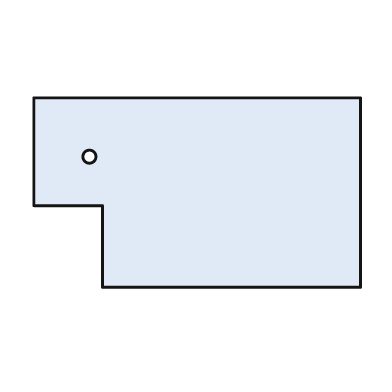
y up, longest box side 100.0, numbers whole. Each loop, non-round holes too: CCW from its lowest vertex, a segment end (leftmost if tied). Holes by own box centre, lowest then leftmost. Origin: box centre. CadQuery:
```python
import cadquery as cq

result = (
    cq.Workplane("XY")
    .moveTo(-29.0, -29.0)
    .lineTo(50.0, -29.0)
    .lineTo(50.0, 29.0)
    .lineTo(-50.0, 29.0)
    .lineTo(-50.0, -4.0)
    .lineTo(-29.0, -4.0)
    .close()
    .moveTo(-33.0, 11.0)
    .circle(2.0)
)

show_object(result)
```